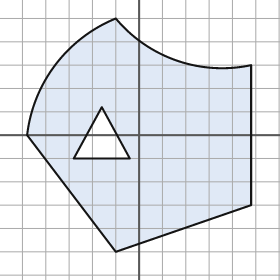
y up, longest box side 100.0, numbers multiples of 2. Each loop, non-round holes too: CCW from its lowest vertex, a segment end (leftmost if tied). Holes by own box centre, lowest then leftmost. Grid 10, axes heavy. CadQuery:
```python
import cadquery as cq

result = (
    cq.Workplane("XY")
    .moveTo(-10.0, -50.0)
    .lineTo(48.0, -30.0)
    .lineTo(48.0, 30.0)
    .threePointArc((16.0, 32.0), (-10.0, 50.0))
    .threePointArc((-36.0, 30.0), (-48.0, 0.0))
    .close()
    .moveTo(-28.0, -10.0)
    .lineTo(-4.0, -10.0)
    .lineTo(-16.0, 12.0)
    .close()
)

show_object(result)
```